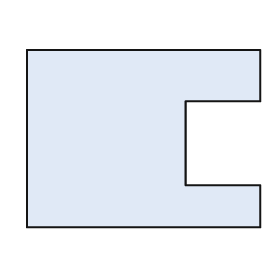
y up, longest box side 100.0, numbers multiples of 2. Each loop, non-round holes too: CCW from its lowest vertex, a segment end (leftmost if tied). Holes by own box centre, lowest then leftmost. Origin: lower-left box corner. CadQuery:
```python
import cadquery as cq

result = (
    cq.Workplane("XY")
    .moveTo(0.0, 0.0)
    .lineTo(100.0, 0.0)
    .lineTo(100.0, 18.0)
    .lineTo(68.0, 18.0)
    .lineTo(68.0, 54.0)
    .lineTo(100.0, 54.0)
    .lineTo(100.0, 76.0)
    .lineTo(0.0, 76.0)
    .close()
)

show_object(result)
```